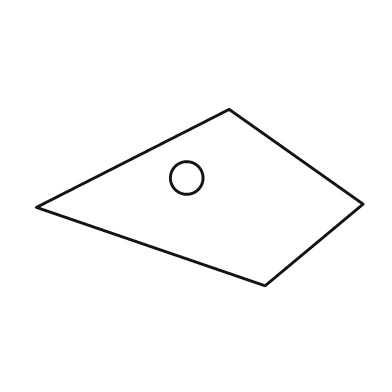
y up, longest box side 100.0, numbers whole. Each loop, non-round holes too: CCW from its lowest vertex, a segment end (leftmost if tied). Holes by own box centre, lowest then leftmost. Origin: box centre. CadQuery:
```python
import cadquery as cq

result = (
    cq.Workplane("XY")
    .moveTo(20.0, -27.0)
    .lineTo(50.0, -2.0)
    .lineTo(9.0, 27.0)
    .lineTo(-50.0, -3.0)
    .close()
    .moveTo(-4.0, 6.0)
    .circle(5.0)
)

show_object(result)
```